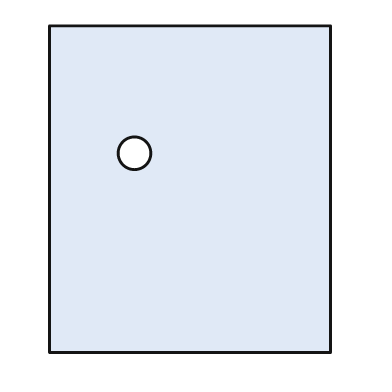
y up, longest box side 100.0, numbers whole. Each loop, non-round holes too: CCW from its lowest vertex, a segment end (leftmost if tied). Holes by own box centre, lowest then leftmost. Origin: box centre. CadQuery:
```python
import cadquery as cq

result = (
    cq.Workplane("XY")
    .moveTo(-43.0, -50.0)
    .lineTo(43.0, -50.0)
    .lineTo(43.0, 50.0)
    .lineTo(-43.0, 50.0)
    .close()
    .moveTo(-17.0, 11.0)
    .circle(5.0)
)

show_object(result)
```